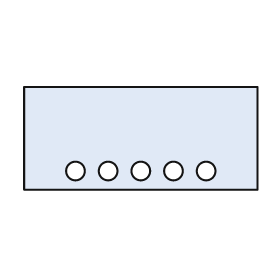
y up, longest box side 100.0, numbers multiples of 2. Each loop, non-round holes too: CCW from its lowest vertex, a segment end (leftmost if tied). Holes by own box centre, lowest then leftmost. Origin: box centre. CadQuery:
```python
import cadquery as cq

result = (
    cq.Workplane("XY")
    .moveTo(-50.0, -22.0)
    .lineTo(50.0, -22.0)
    .lineTo(50.0, 22.0)
    .lineTo(-50.0, 22.0)
    .close()
    .moveTo(-28.0, -14.0)
    .circle(4.0)
    .moveTo(-14.0, -14.0)
    .circle(4.0)
    .moveTo(0.0, -14.0)
    .circle(4.0)
    .moveTo(14.0, -14.0)
    .circle(4.0)
    .moveTo(28.0, -14.0)
    .circle(4.0)
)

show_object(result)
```